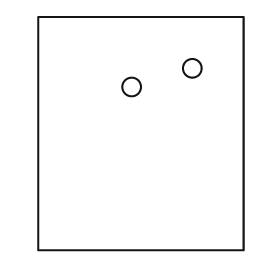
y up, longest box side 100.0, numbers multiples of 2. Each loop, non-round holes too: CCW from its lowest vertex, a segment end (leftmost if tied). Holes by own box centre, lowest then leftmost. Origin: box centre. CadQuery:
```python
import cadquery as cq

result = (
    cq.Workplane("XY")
    .moveTo(-44.0, -50.0)
    .lineTo(44.0, -50.0)
    .lineTo(44.0, 50.0)
    .lineTo(-44.0, 50.0)
    .close()
    .moveTo(-4.0, 20.0)
    .circle(4.0)
    .moveTo(22.0, 28.0)
    .circle(4.0)
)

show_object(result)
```